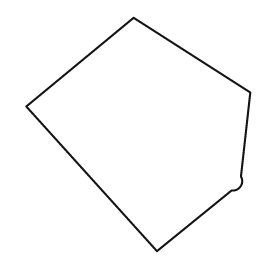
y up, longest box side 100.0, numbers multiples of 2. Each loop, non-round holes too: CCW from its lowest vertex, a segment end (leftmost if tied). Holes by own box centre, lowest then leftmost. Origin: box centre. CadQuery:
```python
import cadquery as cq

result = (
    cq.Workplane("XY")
    .moveTo(8.0, -50.0)
    .lineTo(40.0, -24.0)
    .threePointArc((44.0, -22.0), (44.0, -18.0))
    .lineTo(48.0, 18.0)
    .lineTo(-2.0, 50.0)
    .lineTo(-48.0, 12.0)
    .close()
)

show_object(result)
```